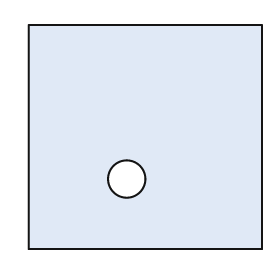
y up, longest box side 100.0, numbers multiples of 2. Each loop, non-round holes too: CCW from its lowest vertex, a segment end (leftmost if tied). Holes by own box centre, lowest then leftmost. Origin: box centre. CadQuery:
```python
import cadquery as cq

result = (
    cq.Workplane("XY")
    .moveTo(-50.0, -48.0)
    .lineTo(50.0, -48.0)
    .lineTo(50.0, 48.0)
    .lineTo(-50.0, 48.0)
    .close()
    .moveTo(-8.0, -18.0)
    .circle(8.0)
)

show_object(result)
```